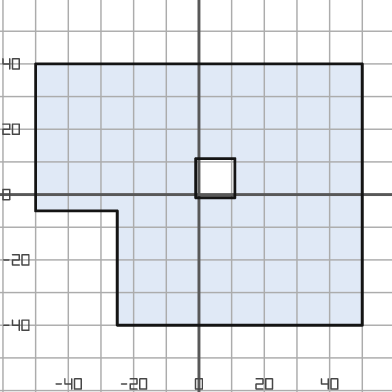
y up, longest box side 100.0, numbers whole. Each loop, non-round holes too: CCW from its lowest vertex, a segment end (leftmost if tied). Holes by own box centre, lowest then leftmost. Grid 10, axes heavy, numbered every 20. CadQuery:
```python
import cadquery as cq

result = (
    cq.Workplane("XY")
    .moveTo(-25.0, -40.0)
    .lineTo(50.0, -40.0)
    .lineTo(50.0, 40.0)
    .lineTo(-50.0, 40.0)
    .lineTo(-50.0, -5.0)
    .lineTo(-25.0, -5.0)
    .close()
    .moveTo(-1.0, -1.0)
    .lineTo(11.0, -1.0)
    .lineTo(11.0, 11.0)
    .lineTo(-1.0, 11.0)
    .close()
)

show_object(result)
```